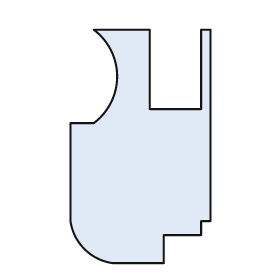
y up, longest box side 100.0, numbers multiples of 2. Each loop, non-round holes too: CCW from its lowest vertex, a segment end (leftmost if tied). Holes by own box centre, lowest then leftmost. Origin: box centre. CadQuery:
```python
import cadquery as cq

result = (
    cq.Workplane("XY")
    .moveTo(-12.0, -50.0)
    .lineTo(10.0, -50.0)
    .lineTo(10.0, -38.0)
    .lineTo(26.0, -38.0)
    .lineTo(26.0, -32.0)
    .lineTo(30.0, -32.0)
    .lineTo(30.0, 50.0)
    .lineTo(26.0, 50.0)
    .lineTo(26.0, 16.0)
    .lineTo(4.0, 16.0)
    .lineTo(4.0, 50.0)
    .lineTo(-20.0, 50.0)
    .threePointArc((-10.0, 30.0), (-20.0, 10.0))
    .lineTo(-30.0, 10.0)
    .lineTo(-30.0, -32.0)
    .threePointArc((-24.0, -44.0), (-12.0, -50.0))
    .close()
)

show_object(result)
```